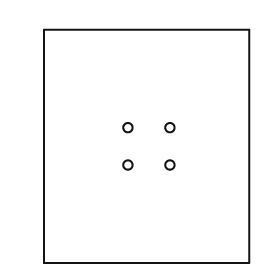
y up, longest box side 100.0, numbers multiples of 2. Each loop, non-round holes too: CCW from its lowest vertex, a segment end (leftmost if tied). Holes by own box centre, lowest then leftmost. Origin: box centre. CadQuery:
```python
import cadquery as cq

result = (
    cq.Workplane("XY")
    .moveTo(-44.0, -50.0)
    .lineTo(44.0, -50.0)
    .lineTo(44.0, 50.0)
    .lineTo(-44.0, 50.0)
    .close()
    .moveTo(-8.0, -8.0)
    .circle(2.0)
    .moveTo(10.0, -8.0)
    .circle(2.0)
    .moveTo(-8.0, 8.0)
    .circle(2.0)
    .moveTo(10.0, 8.0)
    .circle(2.0)
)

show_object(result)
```